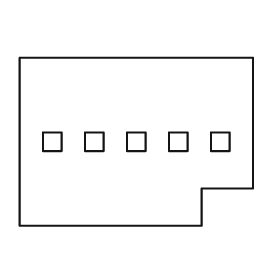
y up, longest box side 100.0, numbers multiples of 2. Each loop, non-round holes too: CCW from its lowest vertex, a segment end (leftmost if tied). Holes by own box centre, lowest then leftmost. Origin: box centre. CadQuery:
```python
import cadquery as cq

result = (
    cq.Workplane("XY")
    .moveTo(-50.0, -36.0)
    .lineTo(28.0, -36.0)
    .lineTo(28.0, -20.0)
    .lineTo(50.0, -20.0)
    .lineTo(50.0, 36.0)
    .lineTo(-50.0, 36.0)
    .close()
    .moveTo(-40.0, -4.0)
    .lineTo(-32.0, -4.0)
    .lineTo(-32.0, 4.0)
    .lineTo(-40.0, 4.0)
    .close()
    .moveTo(-22.0, -4.0)
    .lineTo(-14.0, -4.0)
    .lineTo(-14.0, 4.0)
    .lineTo(-22.0, 4.0)
    .close()
    .moveTo(-4.0, -4.0)
    .lineTo(4.0, -4.0)
    .lineTo(4.0, 4.0)
    .lineTo(-4.0, 4.0)
    .close()
    .moveTo(14.0, -4.0)
    .lineTo(22.0, -4.0)
    .lineTo(22.0, 4.0)
    .lineTo(14.0, 4.0)
    .close()
    .moveTo(32.0, -4.0)
    .lineTo(40.0, -4.0)
    .lineTo(40.0, 4.0)
    .lineTo(32.0, 4.0)
    .close()
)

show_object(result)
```